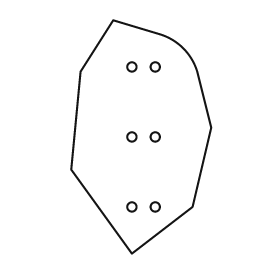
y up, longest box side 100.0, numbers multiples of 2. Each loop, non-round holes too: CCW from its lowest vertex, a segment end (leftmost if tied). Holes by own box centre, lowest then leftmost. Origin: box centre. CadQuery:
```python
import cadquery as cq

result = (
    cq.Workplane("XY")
    .moveTo(-4.0, -50.0)
    .lineTo(22.0, -30.0)
    .lineTo(30.0, 4.0)
    .lineTo(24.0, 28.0)
    .threePointArc((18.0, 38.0), (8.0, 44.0))
    .lineTo(-12.0, 50.0)
    .lineTo(-26.0, 28.0)
    .lineTo(-30.0, -14.0)
    .close()
    .moveTo(-4.0, -30.0)
    .circle(2.0)
    .moveTo(6.0, -30.0)
    .circle(2.0)
    .moveTo(-4.0, 0.0)
    .circle(2.0)
    .moveTo(6.0, 0.0)
    .circle(2.0)
    .moveTo(-4.0, 30.0)
    .circle(2.0)
    .moveTo(6.0, 30.0)
    .circle(2.0)
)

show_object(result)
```